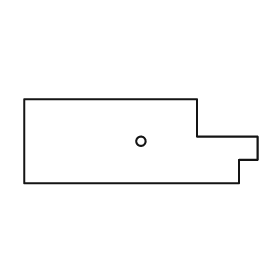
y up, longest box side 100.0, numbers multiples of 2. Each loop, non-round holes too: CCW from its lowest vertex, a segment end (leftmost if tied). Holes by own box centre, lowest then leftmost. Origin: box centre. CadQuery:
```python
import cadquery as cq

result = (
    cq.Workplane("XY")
    .moveTo(-50.0, -18.0)
    .lineTo(42.0, -18.0)
    .lineTo(42.0, -8.0)
    .lineTo(50.0, -8.0)
    .lineTo(50.0, 2.0)
    .lineTo(24.0, 2.0)
    .lineTo(24.0, 18.0)
    .lineTo(-50.0, 18.0)
    .close()
    .moveTo(0.0, 0.0)
    .circle(2.0)
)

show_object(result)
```